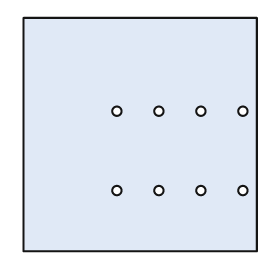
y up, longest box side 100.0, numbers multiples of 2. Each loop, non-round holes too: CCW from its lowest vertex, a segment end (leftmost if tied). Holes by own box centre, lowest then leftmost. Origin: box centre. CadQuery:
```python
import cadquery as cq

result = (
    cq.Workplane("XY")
    .moveTo(-50.0, -50.0)
    .lineTo(50.0, -50.0)
    .lineTo(50.0, 50.0)
    .lineTo(-50.0, 50.0)
    .close()
    .moveTo(-10.0, -24.0)
    .circle(2.0)
    .moveTo(8.0, -24.0)
    .circle(2.0)
    .moveTo(26.0, -24.0)
    .circle(2.0)
    .moveTo(44.0, -24.0)
    .circle(2.0)
    .moveTo(-10.0, 10.0)
    .circle(2.0)
    .moveTo(8.0, 10.0)
    .circle(2.0)
    .moveTo(26.0, 10.0)
    .circle(2.0)
    .moveTo(44.0, 10.0)
    .circle(2.0)
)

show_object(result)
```